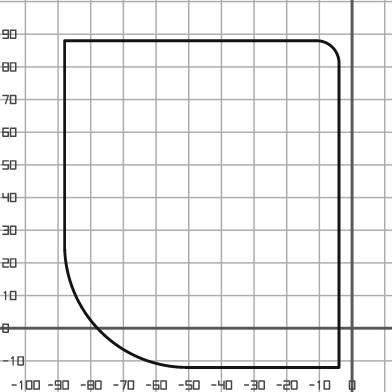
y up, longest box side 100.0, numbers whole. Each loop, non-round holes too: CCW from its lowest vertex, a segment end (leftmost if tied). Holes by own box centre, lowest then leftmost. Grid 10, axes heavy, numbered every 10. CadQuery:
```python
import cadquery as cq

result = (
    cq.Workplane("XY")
    .moveTo(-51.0, -12.0)
    .lineTo(-4.0, -12.0)
    .lineTo(-4.0, 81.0)
    .threePointArc((-6.0, 86.0), (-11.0, 88.0))
    .lineTo(-88.0, 88.0)
    .lineTo(-88.0, 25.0)
    .threePointArc((-77.0, -1.0), (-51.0, -12.0))
    .close()
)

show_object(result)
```